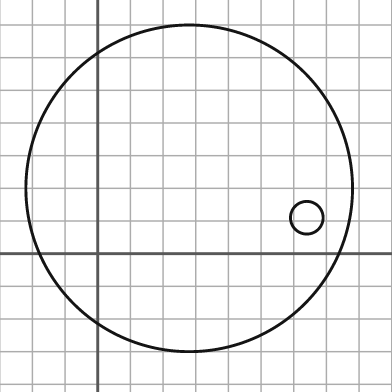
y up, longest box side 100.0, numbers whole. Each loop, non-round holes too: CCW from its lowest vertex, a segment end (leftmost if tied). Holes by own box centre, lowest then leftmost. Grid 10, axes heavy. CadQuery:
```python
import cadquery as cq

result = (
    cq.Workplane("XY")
    .moveTo(28.0, 20.0)
    .circle(50.0)
    .moveTo(64.0, 11.0)
    .circle(5.0)
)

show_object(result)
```